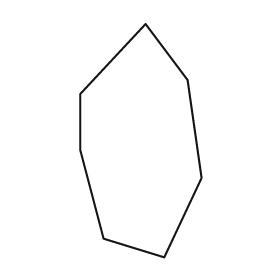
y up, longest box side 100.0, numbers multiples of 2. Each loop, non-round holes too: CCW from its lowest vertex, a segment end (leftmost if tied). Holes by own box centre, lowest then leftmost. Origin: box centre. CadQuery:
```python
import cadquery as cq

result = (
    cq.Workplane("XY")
    .moveTo(10.0, -50.0)
    .lineTo(26.0, -16.0)
    .lineTo(20.0, 26.0)
    .lineTo(2.0, 50.0)
    .lineTo(-26.0, 20.0)
    .lineTo(-26.0, -4.0)
    .lineTo(-16.0, -42.0)
    .close()
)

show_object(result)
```